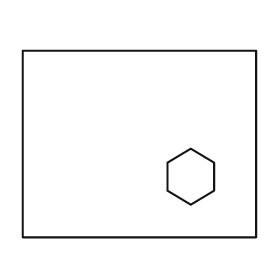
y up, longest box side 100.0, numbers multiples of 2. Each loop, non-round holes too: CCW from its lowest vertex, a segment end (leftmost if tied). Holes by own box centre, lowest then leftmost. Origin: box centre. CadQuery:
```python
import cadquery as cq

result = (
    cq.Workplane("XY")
    .moveTo(-50.0, -40.0)
    .lineTo(50.0, -40.0)
    .lineTo(50.0, 40.0)
    .lineTo(-50.0, 40.0)
    .close()
    .moveTo(22.0, -26.0)
    .lineTo(32.0, -20.0)
    .lineTo(32.0, -8.0)
    .lineTo(22.0, -2.0)
    .lineTo(12.0, -8.0)
    .lineTo(12.0, -20.0)
    .close()
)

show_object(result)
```